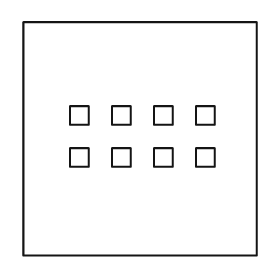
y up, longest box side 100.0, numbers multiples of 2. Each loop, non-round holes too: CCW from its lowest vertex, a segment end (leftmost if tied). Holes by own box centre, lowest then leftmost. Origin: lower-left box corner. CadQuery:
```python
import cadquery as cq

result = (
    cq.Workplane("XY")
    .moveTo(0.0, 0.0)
    .lineTo(100.0, 0.0)
    .lineTo(100.0, 100.0)
    .lineTo(0.0, 100.0)
    .close()
    .moveTo(20.0, 38.0)
    .lineTo(28.0, 38.0)
    .lineTo(28.0, 46.0)
    .lineTo(20.0, 46.0)
    .close()
    .moveTo(38.0, 38.0)
    .lineTo(46.0, 38.0)
    .lineTo(46.0, 46.0)
    .lineTo(38.0, 46.0)
    .close()
    .moveTo(56.0, 38.0)
    .lineTo(64.0, 38.0)
    .lineTo(64.0, 46.0)
    .lineTo(56.0, 46.0)
    .close()
    .moveTo(74.0, 38.0)
    .lineTo(82.0, 38.0)
    .lineTo(82.0, 46.0)
    .lineTo(74.0, 46.0)
    .close()
    .moveTo(20.0, 56.0)
    .lineTo(28.0, 56.0)
    .lineTo(28.0, 64.0)
    .lineTo(20.0, 64.0)
    .close()
    .moveTo(38.0, 56.0)
    .lineTo(46.0, 56.0)
    .lineTo(46.0, 64.0)
    .lineTo(38.0, 64.0)
    .close()
    .moveTo(56.0, 56.0)
    .lineTo(64.0, 56.0)
    .lineTo(64.0, 64.0)
    .lineTo(56.0, 64.0)
    .close()
    .moveTo(74.0, 56.0)
    .lineTo(82.0, 56.0)
    .lineTo(82.0, 64.0)
    .lineTo(74.0, 64.0)
    .close()
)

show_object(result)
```